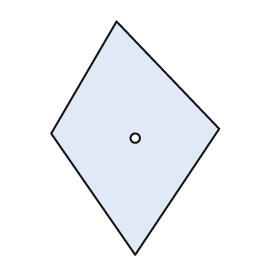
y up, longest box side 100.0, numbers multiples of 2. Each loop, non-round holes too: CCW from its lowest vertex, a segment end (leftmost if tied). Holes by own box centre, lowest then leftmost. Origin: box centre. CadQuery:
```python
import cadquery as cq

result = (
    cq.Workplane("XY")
    .moveTo(0.0, -50.0)
    .lineTo(36.0, 4.0)
    .lineTo(-8.0, 50.0)
    .lineTo(-36.0, 2.0)
    .close()
    .moveTo(0.0, 0.0)
    .circle(2.0)
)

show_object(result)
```